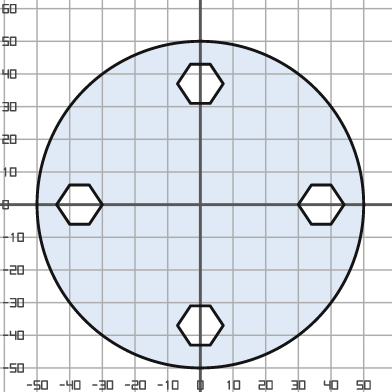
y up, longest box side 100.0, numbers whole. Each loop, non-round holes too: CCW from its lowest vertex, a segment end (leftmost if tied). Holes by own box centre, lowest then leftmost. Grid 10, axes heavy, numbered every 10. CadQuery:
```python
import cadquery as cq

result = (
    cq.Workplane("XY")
    .moveTo(0.0, 0.0)
    .circle(50.0)
    .moveTo(-3.0, -43.0)
    .lineTo(3.0, -43.0)
    .lineTo(7.0, -37.0)
    .lineTo(3.0, -31.0)
    .lineTo(-3.0, -31.0)
    .lineTo(-7.0, -37.0)
    .close()
    .moveTo(-40.0, -6.0)
    .lineTo(-34.0, -6.0)
    .lineTo(-30.0, 0.0)
    .lineTo(-34.0, 6.0)
    .lineTo(-40.0, 6.0)
    .lineTo(-44.0, 0.0)
    .close()
    .moveTo(34.0, -6.0)
    .lineTo(40.0, -6.0)
    .lineTo(44.0, 0.0)
    .lineTo(40.0, 6.0)
    .lineTo(34.0, 6.0)
    .lineTo(30.0, 0.0)
    .close()
    .moveTo(-3.0, 31.0)
    .lineTo(3.0, 31.0)
    .lineTo(7.0, 37.0)
    .lineTo(3.0, 43.0)
    .lineTo(-3.0, 43.0)
    .lineTo(-7.0, 37.0)
    .close()
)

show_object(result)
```